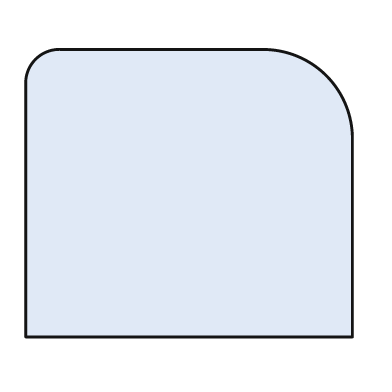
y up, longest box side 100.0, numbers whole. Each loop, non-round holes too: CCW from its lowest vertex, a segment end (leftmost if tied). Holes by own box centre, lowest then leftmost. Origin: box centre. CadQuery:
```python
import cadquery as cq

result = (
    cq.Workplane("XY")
    .moveTo(-50.0, -44.0)
    .lineTo(50.0, -44.0)
    .lineTo(50.0, 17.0)
    .threePointArc((42.0, 36.0), (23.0, 44.0))
    .lineTo(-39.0, 44.0)
    .threePointArc((-47.0, 41.0), (-50.0, 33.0))
    .close()
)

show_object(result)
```